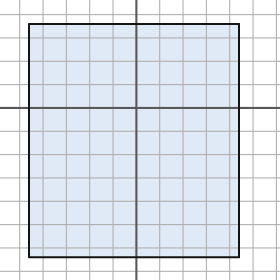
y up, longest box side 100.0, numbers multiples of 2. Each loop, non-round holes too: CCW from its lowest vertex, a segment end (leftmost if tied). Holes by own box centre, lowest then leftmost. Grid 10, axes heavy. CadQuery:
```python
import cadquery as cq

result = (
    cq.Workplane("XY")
    .moveTo(-46.0, -64.0)
    .lineTo(44.0, -64.0)
    .lineTo(44.0, 36.0)
    .lineTo(-46.0, 36.0)
    .close()
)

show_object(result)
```